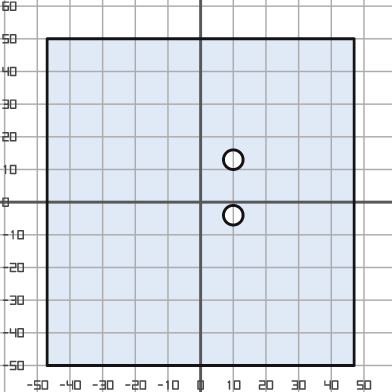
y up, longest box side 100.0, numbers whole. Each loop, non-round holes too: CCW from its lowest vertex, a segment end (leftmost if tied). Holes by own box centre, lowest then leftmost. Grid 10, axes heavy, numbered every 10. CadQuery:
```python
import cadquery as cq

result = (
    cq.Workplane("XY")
    .moveTo(-47.0, -50.0)
    .lineTo(47.0, -50.0)
    .lineTo(47.0, 50.0)
    .lineTo(-47.0, 50.0)
    .close()
    .moveTo(10.0, -4.0)
    .circle(3.0)
    .moveTo(10.0, 13.0)
    .circle(3.0)
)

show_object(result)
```